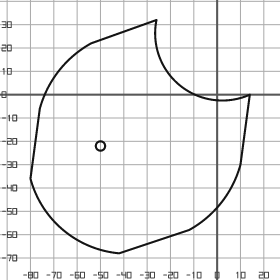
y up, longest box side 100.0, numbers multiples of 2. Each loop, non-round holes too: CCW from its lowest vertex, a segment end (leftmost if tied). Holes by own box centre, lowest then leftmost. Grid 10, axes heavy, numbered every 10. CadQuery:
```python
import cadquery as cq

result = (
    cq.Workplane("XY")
    .moveTo(-42.0, -68.0)
    .lineTo(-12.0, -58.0)
    .threePointArc((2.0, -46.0), (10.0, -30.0))
    .lineTo(14.0, 0.0)
    .threePointArc((-16.0, 4.0), (-26.0, 32.0))
    .lineTo(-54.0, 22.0)
    .threePointArc((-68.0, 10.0), (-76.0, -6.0))
    .lineTo(-80.0, -36.0)
    .threePointArc((-66.0, -58.0), (-42.0, -68.0))
    .close()
    .moveTo(-50.0, -22.0)
    .circle(2.0)
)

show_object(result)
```